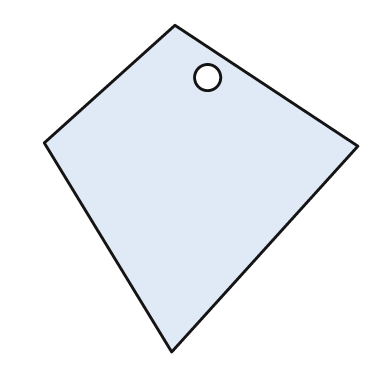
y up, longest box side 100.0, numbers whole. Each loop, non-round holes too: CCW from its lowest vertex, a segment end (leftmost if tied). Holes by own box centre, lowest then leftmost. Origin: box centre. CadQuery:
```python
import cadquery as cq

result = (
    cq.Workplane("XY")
    .moveTo(-9.0, -50.0)
    .lineTo(48.0, 13.0)
    .lineTo(-8.0, 50.0)
    .lineTo(-48.0, 14.0)
    .close()
    .moveTo(2.0, 34.0)
    .circle(4.0)
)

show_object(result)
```